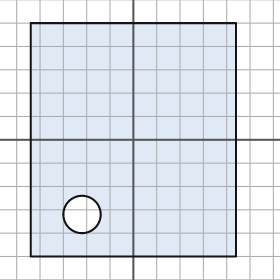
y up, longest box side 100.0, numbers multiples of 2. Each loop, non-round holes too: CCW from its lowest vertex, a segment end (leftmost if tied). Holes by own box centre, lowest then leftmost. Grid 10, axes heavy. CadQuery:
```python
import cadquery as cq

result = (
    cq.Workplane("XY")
    .moveTo(-44.0, -50.0)
    .lineTo(44.0, -50.0)
    .lineTo(44.0, 50.0)
    .lineTo(-44.0, 50.0)
    .close()
    .moveTo(-22.0, -32.0)
    .circle(8.0)
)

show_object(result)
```